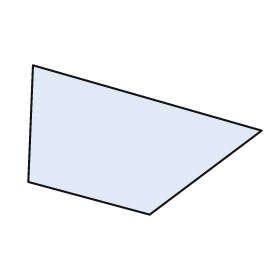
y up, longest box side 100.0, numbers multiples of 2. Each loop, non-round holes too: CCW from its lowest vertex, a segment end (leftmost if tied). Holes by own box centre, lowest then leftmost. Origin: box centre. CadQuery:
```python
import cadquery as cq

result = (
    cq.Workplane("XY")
    .moveTo(2.0, -32.0)
    .lineTo(50.0, 4.0)
    .lineTo(-48.0, 32.0)
    .lineTo(-50.0, -18.0)
    .close()
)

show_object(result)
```